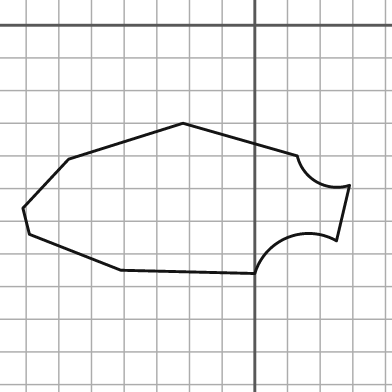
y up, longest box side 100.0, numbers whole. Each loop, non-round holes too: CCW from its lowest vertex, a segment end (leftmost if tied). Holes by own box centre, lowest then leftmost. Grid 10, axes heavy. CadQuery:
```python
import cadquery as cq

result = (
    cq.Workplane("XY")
    .moveTo(0.0, -76.0)
    .threePointArc((10.0, -65.0), (25.0, -66.0))
    .lineTo(29.0, -49.0)
    .threePointArc((19.0, -48.0), (13.0, -40.0))
    .lineTo(-22.0, -30.0)
    .lineTo(-57.0, -41.0)
    .lineTo(-71.0, -56.0)
    .lineTo(-69.0, -64.0)
    .lineTo(-41.0, -75.0)
    .close()
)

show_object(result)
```